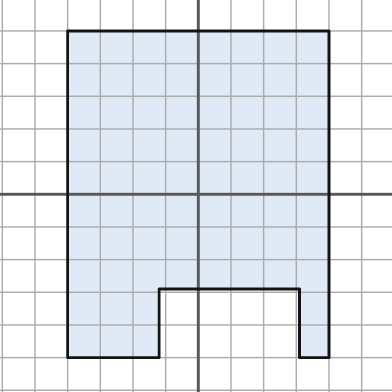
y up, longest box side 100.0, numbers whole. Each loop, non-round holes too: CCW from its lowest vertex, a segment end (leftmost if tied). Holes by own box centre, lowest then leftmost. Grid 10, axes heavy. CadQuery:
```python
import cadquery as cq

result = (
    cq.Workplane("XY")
    .moveTo(-40.0, -50.0)
    .lineTo(-12.0, -50.0)
    .lineTo(-12.0, -29.0)
    .lineTo(31.0, -29.0)
    .lineTo(31.0, -50.0)
    .lineTo(40.0, -50.0)
    .lineTo(40.0, 50.0)
    .lineTo(-40.0, 50.0)
    .close()
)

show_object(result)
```